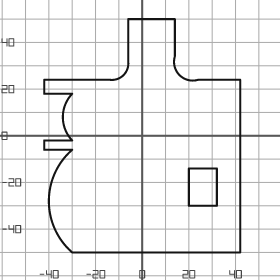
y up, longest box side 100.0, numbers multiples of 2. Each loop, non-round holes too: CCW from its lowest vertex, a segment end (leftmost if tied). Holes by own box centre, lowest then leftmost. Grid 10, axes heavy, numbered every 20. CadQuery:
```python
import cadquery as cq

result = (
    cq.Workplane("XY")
    .moveTo(-30.0, -50.0)
    .lineTo(42.0, -50.0)
    .lineTo(42.0, 24.0)
    .lineTo(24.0, 24.0)
    .threePointArc((16.0, 26.0), (14.0, 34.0))
    .lineTo(14.0, 50.0)
    .lineTo(-6.0, 50.0)
    .lineTo(-6.0, 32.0)
    .threePointArc((-8.0, 26.0), (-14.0, 24.0))
    .lineTo(-42.0, 24.0)
    .lineTo(-42.0, 18.0)
    .lineTo(-30.0, 18.0)
    .threePointArc((-34.0, 8.0), (-30.0, -2.0))
    .lineTo(-42.0, -2.0)
    .lineTo(-42.0, -6.0)
    .lineTo(-30.0, -6.0)
    .threePointArc((-40.0, -28.0), (-30.0, -50.0))
    .close()
    .moveTo(20.0, -30.0)
    .lineTo(32.0, -30.0)
    .lineTo(32.0, -14.0)
    .lineTo(20.0, -14.0)
    .close()
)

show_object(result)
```